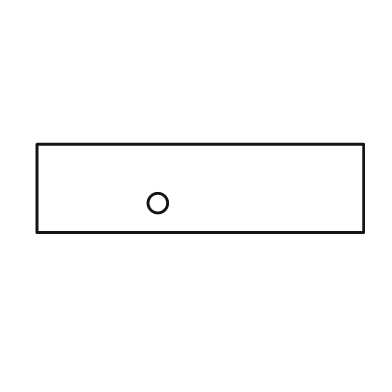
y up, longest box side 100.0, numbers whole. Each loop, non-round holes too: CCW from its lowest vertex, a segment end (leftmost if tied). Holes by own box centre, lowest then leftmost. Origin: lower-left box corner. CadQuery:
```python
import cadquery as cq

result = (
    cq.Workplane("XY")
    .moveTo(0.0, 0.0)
    .lineTo(100.0, 0.0)
    .lineTo(100.0, 27.0)
    .lineTo(0.0, 27.0)
    .close()
    .moveTo(37.0, 9.0)
    .circle(3.0)
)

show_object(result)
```